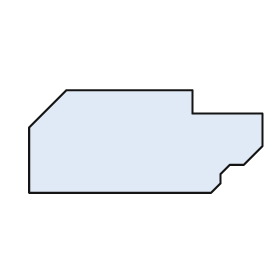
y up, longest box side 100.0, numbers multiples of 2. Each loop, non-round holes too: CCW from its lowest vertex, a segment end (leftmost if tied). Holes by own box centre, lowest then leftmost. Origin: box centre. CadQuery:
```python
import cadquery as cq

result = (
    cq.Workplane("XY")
    .moveTo(-50.0, -22.0)
    .lineTo(28.0, -22.0)
    .lineTo(32.0, -18.0)
    .lineTo(32.0, -14.0)
    .lineTo(36.0, -10.0)
    .lineTo(42.0, -10.0)
    .lineTo(50.0, -2.0)
    .lineTo(50.0, 12.0)
    .lineTo(20.0, 12.0)
    .lineTo(20.0, 22.0)
    .lineTo(-34.0, 22.0)
    .lineTo(-50.0, 6.0)
    .close()
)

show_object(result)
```